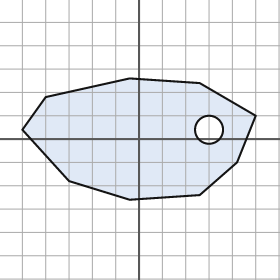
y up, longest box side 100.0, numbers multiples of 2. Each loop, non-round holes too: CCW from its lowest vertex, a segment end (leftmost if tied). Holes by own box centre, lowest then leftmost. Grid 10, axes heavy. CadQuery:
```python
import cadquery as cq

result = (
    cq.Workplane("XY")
    .moveTo(-4.0, -26.0)
    .lineTo(26.0, -24.0)
    .lineTo(42.0, -10.0)
    .lineTo(50.0, 10.0)
    .lineTo(26.0, 24.0)
    .lineTo(-4.0, 26.0)
    .lineTo(-40.0, 18.0)
    .lineTo(-50.0, 4.0)
    .lineTo(-30.0, -18.0)
    .close()
    .moveTo(30.0, 4.0)
    .circle(6.0)
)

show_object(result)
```